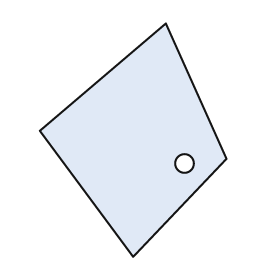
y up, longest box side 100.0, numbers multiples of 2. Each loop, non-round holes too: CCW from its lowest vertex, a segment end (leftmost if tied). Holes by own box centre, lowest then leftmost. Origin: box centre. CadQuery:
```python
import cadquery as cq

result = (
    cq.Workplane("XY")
    .moveTo(0.0, -50.0)
    .lineTo(40.0, -8.0)
    .lineTo(14.0, 50.0)
    .lineTo(-40.0, 4.0)
    .close()
    .moveTo(22.0, -10.0)
    .circle(4.0)
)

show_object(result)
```